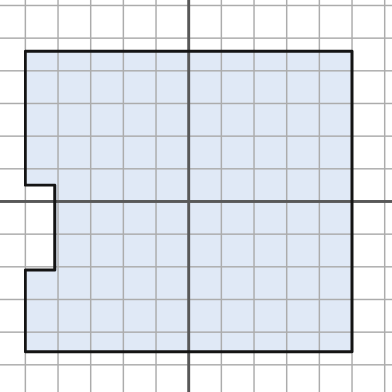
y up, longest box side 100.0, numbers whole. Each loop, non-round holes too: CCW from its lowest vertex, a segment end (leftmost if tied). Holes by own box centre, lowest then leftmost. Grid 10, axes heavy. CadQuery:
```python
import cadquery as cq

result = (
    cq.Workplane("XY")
    .moveTo(-50.0, -46.0)
    .lineTo(50.0, -46.0)
    .lineTo(50.0, 46.0)
    .lineTo(-50.0, 46.0)
    .lineTo(-50.0, 5.0)
    .lineTo(-41.0, 5.0)
    .lineTo(-41.0, -21.0)
    .lineTo(-50.0, -21.0)
    .close()
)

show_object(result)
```